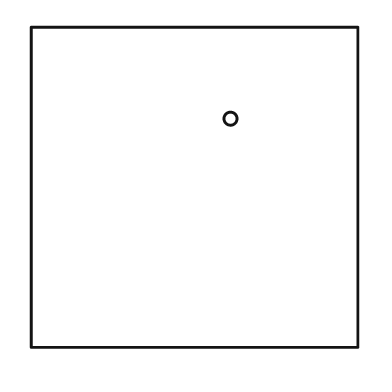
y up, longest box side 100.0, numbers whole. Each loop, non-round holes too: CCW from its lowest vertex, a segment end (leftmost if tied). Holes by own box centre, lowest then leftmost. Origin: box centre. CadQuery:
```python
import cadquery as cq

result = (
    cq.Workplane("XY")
    .moveTo(-50.0, -49.0)
    .lineTo(50.0, -49.0)
    .lineTo(50.0, 49.0)
    .lineTo(-50.0, 49.0)
    .close()
    .moveTo(11.0, 21.0)
    .circle(2.0)
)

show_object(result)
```